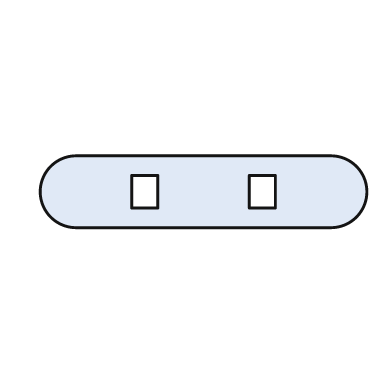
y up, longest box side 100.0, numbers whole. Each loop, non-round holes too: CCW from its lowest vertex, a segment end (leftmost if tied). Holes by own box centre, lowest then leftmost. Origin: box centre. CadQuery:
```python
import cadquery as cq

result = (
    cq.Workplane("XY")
    .moveTo(-39.0, -11.0)
    .lineTo(39.0, -11.0)
    .threePointArc((50.0, 0.0), (39.0, 11.0))
    .lineTo(-39.0, 11.0)
    .threePointArc((-50.0, 0.0), (-39.0, -11.0))
    .close()
    .moveTo(-22.0, -5.0)
    .lineTo(-14.0, -5.0)
    .lineTo(-14.0, 5.0)
    .lineTo(-22.0, 5.0)
    .close()
    .moveTo(14.0, -5.0)
    .lineTo(22.0, -5.0)
    .lineTo(22.0, 5.0)
    .lineTo(14.0, 5.0)
    .close()
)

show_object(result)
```